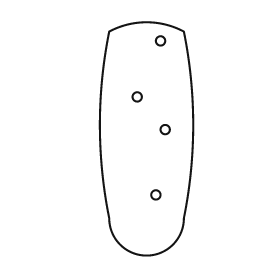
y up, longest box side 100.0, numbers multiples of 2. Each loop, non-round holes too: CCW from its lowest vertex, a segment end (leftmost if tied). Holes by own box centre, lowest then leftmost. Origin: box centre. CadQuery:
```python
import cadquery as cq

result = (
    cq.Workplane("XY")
    .moveTo(-16.0, -34.0)
    .threePointArc((0.0, -50.0), (16.0, -34.0))
    .threePointArc((20.0, 6.0), (16.0, 46.0))
    .threePointArc((0.0, 50.0), (-16.0, 46.0))
    .threePointArc((-20.0, 6.0), (-16.0, -34.0))
    .close()
    .moveTo(4.0, -24.0)
    .circle(2.0)
    .moveTo(8.0, 4.0)
    .circle(2.0)
    .moveTo(-4.0, 18.0)
    .circle(2.0)
    .moveTo(6.0, 42.0)
    .circle(2.0)
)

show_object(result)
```